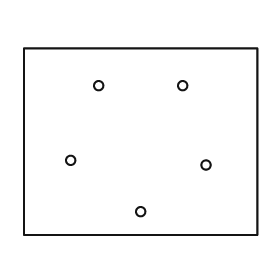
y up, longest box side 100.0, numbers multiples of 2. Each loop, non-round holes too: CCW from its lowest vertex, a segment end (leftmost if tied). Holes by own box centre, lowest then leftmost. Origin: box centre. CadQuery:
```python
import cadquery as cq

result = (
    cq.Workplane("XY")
    .moveTo(-50.0, -40.0)
    .lineTo(50.0, -40.0)
    .lineTo(50.0, 40.0)
    .lineTo(-50.0, 40.0)
    .close()
    .moveTo(0.0, -30.0)
    .circle(2.0)
    .moveTo(28.0, -10.0)
    .circle(2.0)
    .moveTo(-30.0, -8.0)
    .circle(2.0)
    .moveTo(-18.0, 24.0)
    .circle(2.0)
    .moveTo(18.0, 24.0)
    .circle(2.0)
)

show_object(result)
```